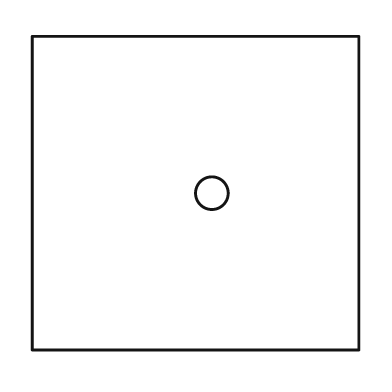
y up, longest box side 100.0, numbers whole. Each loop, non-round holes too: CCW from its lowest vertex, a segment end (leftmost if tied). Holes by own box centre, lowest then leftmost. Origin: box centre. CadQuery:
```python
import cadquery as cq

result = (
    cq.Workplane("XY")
    .moveTo(-50.0, -48.0)
    .lineTo(50.0, -48.0)
    .lineTo(50.0, 48.0)
    .lineTo(-50.0, 48.0)
    .close()
    .moveTo(5.0, 0.0)
    .circle(5.0)
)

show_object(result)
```